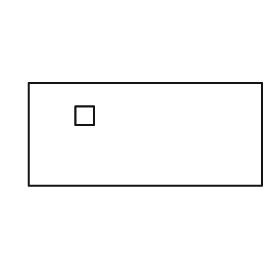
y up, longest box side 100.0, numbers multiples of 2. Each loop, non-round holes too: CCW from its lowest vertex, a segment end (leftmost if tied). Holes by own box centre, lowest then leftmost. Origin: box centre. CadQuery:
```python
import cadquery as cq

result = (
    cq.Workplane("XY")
    .moveTo(-50.0, -22.0)
    .lineTo(50.0, -22.0)
    .lineTo(50.0, 22.0)
    .lineTo(-50.0, 22.0)
    .close()
    .moveTo(-30.0, 4.0)
    .lineTo(-22.0, 4.0)
    .lineTo(-22.0, 12.0)
    .lineTo(-30.0, 12.0)
    .close()
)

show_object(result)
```